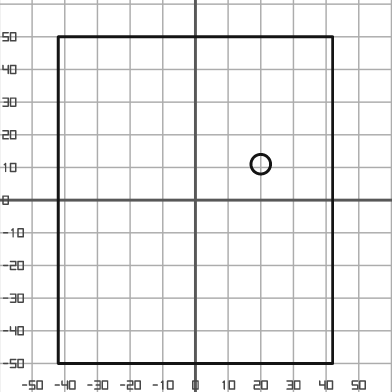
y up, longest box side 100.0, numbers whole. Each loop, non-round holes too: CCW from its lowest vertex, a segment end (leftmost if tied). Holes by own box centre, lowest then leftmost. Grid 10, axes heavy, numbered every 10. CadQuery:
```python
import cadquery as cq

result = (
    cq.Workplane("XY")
    .moveTo(-42.0, -50.0)
    .lineTo(42.0, -50.0)
    .lineTo(42.0, 50.0)
    .lineTo(-42.0, 50.0)
    .close()
    .moveTo(20.0, 11.0)
    .circle(3.0)
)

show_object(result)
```